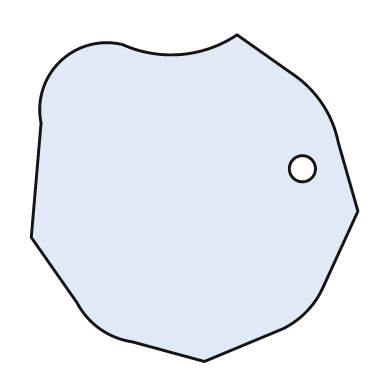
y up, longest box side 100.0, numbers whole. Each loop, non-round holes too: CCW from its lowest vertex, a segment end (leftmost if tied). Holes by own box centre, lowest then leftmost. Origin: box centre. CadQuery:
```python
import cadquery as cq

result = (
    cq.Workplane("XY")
    .moveTo(3.0, -50.0)
    .lineTo(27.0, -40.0)
    .threePointArc((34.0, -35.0), (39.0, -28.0))
    .lineTo(50.0, -4.0)
    .lineTo(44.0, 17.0)
    .threePointArc((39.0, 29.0), (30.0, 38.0))
    .lineTo(13.0, 50.0)
    .threePointArc((-4.0, 44.0), (-22.0, 47.0))
    .threePointArc((-41.0, 42.0), (-47.0, 23.0))
    .lineTo(-50.0, -12.0)
    .lineTo(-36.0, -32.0)
    .threePointArc((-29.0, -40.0), (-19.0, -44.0))
    .close()
    .moveTo(33.0, 9.0)
    .circle(4.0)
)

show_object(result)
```